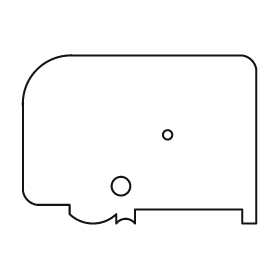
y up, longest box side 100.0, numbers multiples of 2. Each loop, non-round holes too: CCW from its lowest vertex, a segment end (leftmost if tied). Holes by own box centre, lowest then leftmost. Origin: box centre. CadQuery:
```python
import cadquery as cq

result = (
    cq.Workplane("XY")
    .moveTo(-10.0, -36.0)
    .threePointArc((-6.0, -34.0), (-2.0, -36.0))
    .lineTo(-2.0, -30.0)
    .lineTo(44.0, -30.0)
    .lineTo(44.0, -36.0)
    .lineTo(50.0, -36.0)
    .lineTo(50.0, 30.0)
    .threePointArc((48.0, 34.0), (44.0, 36.0))
    .lineTo(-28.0, 36.0)
    .threePointArc((-44.0, 30.0), (-50.0, 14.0))
    .lineTo(-50.0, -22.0)
    .threePointArc((-48.0, -26.0), (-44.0, -28.0))
    .lineTo(-30.0, -28.0)
    .lineTo(-30.0, -32.0)
    .threePointArc((-20.0, -36.0), (-10.0, -32.0))
    .close()
    .moveTo(-8.0, -20.0)
    .circle(4.0)
    .moveTo(12.0, 2.0)
    .circle(2.0)
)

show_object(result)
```